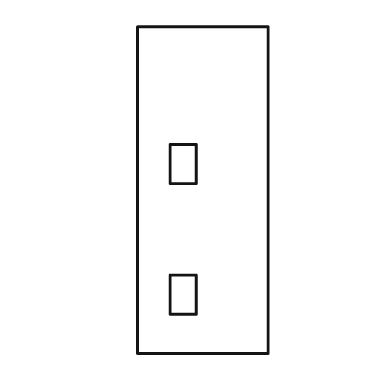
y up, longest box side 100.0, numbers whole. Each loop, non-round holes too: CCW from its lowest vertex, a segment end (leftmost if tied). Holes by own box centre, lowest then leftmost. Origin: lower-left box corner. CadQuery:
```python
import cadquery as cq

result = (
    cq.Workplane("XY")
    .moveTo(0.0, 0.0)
    .lineTo(40.0, 0.0)
    .lineTo(40.0, 100.0)
    .lineTo(0.0, 100.0)
    .close()
    .moveTo(10.0, 12.0)
    .lineTo(18.0, 12.0)
    .lineTo(18.0, 24.0)
    .lineTo(10.0, 24.0)
    .close()
    .moveTo(10.0, 52.0)
    .lineTo(18.0, 52.0)
    .lineTo(18.0, 64.0)
    .lineTo(10.0, 64.0)
    .close()
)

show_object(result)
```